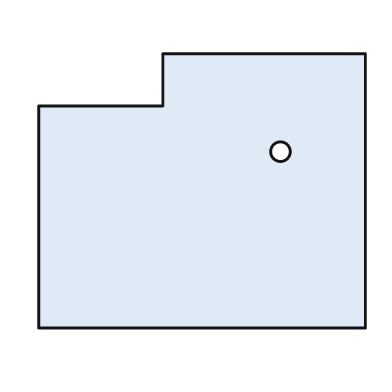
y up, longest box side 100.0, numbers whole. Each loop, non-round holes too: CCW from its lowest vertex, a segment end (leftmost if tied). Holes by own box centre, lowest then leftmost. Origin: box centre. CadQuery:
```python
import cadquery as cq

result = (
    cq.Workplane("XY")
    .moveTo(-50.0, -42.0)
    .lineTo(50.0, -42.0)
    .lineTo(50.0, 42.0)
    .lineTo(-12.0, 42.0)
    .lineTo(-12.0, 26.0)
    .lineTo(-50.0, 26.0)
    .close()
    .moveTo(24.0, 12.0)
    .circle(3.0)
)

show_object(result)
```